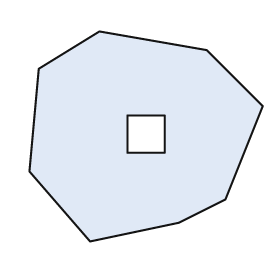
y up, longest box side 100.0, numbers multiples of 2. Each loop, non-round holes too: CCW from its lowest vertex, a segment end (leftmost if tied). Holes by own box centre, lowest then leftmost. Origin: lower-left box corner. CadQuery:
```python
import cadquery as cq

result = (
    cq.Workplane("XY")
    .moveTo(26.0, 0.0)
    .lineTo(64.0, 8.0)
    .lineTo(84.0, 18.0)
    .lineTo(100.0, 58.0)
    .lineTo(76.0, 82.0)
    .lineTo(30.0, 90.0)
    .lineTo(4.0, 74.0)
    .lineTo(0.0, 30.0)
    .close()
    .moveTo(42.0, 38.0)
    .lineTo(58.0, 38.0)
    .lineTo(58.0, 54.0)
    .lineTo(42.0, 54.0)
    .close()
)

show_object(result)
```